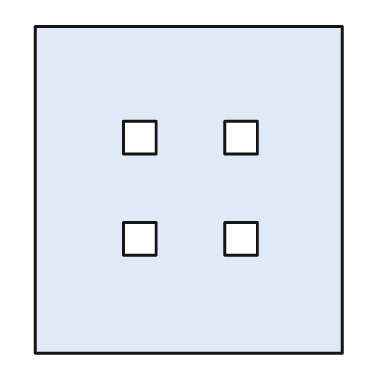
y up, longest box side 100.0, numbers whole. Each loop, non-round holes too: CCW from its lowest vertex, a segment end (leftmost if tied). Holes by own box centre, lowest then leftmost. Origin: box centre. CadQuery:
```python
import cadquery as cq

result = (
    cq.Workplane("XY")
    .moveTo(-47.0, -50.0)
    .lineTo(47.0, -50.0)
    .lineTo(47.0, 50.0)
    .lineTo(-47.0, 50.0)
    .close()
    .moveTo(-20.0, -20.0)
    .lineTo(-10.0, -20.0)
    .lineTo(-10.0, -10.0)
    .lineTo(-20.0, -10.0)
    .close()
    .moveTo(11.0, -20.0)
    .lineTo(21.0, -20.0)
    .lineTo(21.0, -10.0)
    .lineTo(11.0, -10.0)
    .close()
    .moveTo(-20.0, 11.0)
    .lineTo(-10.0, 11.0)
    .lineTo(-10.0, 21.0)
    .lineTo(-20.0, 21.0)
    .close()
    .moveTo(11.0, 11.0)
    .lineTo(21.0, 11.0)
    .lineTo(21.0, 21.0)
    .lineTo(11.0, 21.0)
    .close()
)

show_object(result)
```